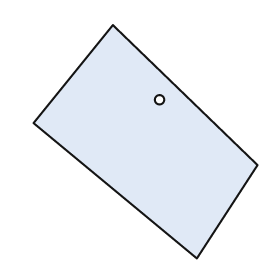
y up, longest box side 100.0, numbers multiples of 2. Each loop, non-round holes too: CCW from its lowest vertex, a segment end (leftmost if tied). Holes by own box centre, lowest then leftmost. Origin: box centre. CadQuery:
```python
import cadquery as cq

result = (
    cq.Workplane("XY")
    .moveTo(22.0, -50.0)
    .lineTo(48.0, -10.0)
    .lineTo(-14.0, 50.0)
    .lineTo(-48.0, 8.0)
    .close()
    .moveTo(6.0, 18.0)
    .circle(2.0)
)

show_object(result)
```